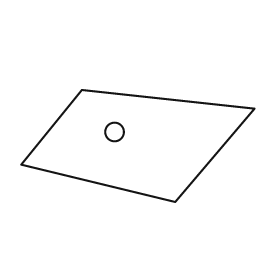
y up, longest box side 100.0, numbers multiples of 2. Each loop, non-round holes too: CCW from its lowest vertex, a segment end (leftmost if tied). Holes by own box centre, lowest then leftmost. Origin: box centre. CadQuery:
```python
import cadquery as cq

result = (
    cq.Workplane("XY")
    .moveTo(16.0, -24.0)
    .lineTo(50.0, 16.0)
    .lineTo(-24.0, 24.0)
    .lineTo(-50.0, -8.0)
    .close()
    .moveTo(-10.0, 6.0)
    .circle(4.0)
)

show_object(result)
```